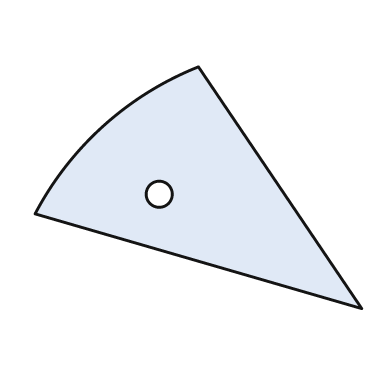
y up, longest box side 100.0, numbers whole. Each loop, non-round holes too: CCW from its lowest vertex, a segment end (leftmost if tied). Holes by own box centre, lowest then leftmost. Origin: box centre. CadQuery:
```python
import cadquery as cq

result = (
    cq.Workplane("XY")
    .moveTo(50.0, -37.0)
    .lineTo(0.0, 37.0)
    .threePointArc((-29.0, 19.0), (-50.0, -8.0))
    .close()
    .moveTo(-12.0, -2.0)
    .circle(4.0)
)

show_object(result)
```